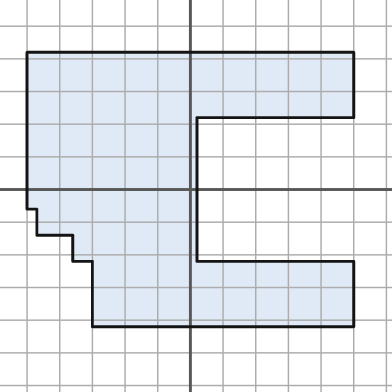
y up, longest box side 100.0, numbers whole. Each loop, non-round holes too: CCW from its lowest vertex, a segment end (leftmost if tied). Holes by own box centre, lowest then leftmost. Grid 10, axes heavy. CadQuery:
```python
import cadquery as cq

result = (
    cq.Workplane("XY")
    .moveTo(-30.0, -42.0)
    .lineTo(50.0, -42.0)
    .lineTo(50.0, -22.0)
    .lineTo(2.0, -22.0)
    .lineTo(2.0, 22.0)
    .lineTo(50.0, 22.0)
    .lineTo(50.0, 42.0)
    .lineTo(-50.0, 42.0)
    .lineTo(-50.0, -6.0)
    .lineTo(-47.0, -6.0)
    .lineTo(-47.0, -14.0)
    .lineTo(-36.0, -14.0)
    .lineTo(-36.0, -22.0)
    .lineTo(-30.0, -22.0)
    .close()
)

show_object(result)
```